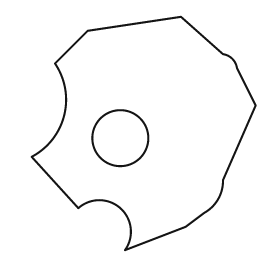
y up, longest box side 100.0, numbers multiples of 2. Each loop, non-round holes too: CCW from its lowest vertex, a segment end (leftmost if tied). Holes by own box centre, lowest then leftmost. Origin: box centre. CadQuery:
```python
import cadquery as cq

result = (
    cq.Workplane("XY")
    .moveTo(-8.0, -50.0)
    .lineTo(18.0, -40.0)
    .lineTo(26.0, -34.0)
    .threePointArc((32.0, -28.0), (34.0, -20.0))
    .lineTo(48.0, 12.0)
    .lineTo(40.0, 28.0)
    .threePointArc((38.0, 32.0), (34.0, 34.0))
    .lineTo(16.0, 50.0)
    .lineTo(-24.0, 44.0)
    .lineTo(-38.0, 30.0)
    .threePointArc((-34.0, 8.0), (-48.0, -10.0))
    .lineTo(-28.0, -32.0)
    .threePointArc((-10.0, -32.0), (-8.0, -50.0))
    .close()
    .moveTo(-10.0, -2.0)
    .circle(12.0)
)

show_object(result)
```